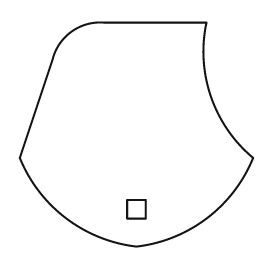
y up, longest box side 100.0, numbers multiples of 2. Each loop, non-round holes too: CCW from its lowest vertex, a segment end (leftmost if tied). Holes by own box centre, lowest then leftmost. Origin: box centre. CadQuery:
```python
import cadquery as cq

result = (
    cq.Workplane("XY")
    .moveTo(0.0, -48.0)
    .threePointArc((30.0, -36.0), (50.0, -10.0))
    .threePointArc((32.0, 16.0), (30.0, 48.0))
    .lineTo(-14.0, 48.0)
    .threePointArc((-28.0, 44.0), (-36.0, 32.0))
    .lineTo(-50.0, -10.0)
    .threePointArc((-30.0, -36.0), (0.0, -48.0))
    .close()
    .moveTo(-4.0, -36.0)
    .lineTo(4.0, -36.0)
    .lineTo(4.0, -28.0)
    .lineTo(-4.0, -28.0)
    .close()
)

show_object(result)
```